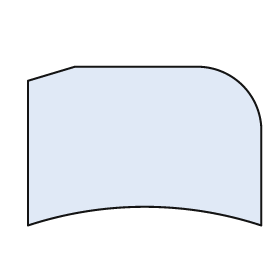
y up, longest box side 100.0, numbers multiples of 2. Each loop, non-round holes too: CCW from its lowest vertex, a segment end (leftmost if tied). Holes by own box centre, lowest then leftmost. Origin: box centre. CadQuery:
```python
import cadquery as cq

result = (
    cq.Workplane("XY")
    .moveTo(-50.0, -34.0)
    .threePointArc((0.0, -26.0), (50.0, -34.0))
    .lineTo(50.0, 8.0)
    .threePointArc((42.0, 26.0), (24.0, 34.0))
    .lineTo(-30.0, 34.0)
    .lineTo(-50.0, 28.0)
    .close()
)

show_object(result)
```